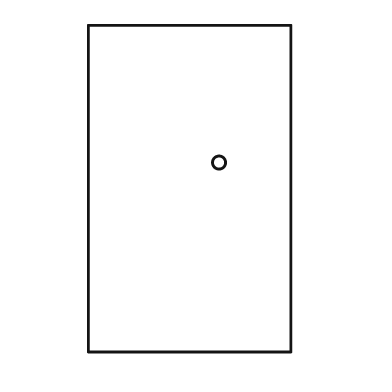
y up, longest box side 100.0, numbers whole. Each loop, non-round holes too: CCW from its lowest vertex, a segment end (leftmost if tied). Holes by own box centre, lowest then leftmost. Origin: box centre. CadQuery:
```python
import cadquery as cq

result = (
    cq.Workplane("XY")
    .moveTo(-31.0, -50.0)
    .lineTo(31.0, -50.0)
    .lineTo(31.0, 50.0)
    .lineTo(-31.0, 50.0)
    .close()
    .moveTo(9.0, 8.0)
    .circle(2.0)
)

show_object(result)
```